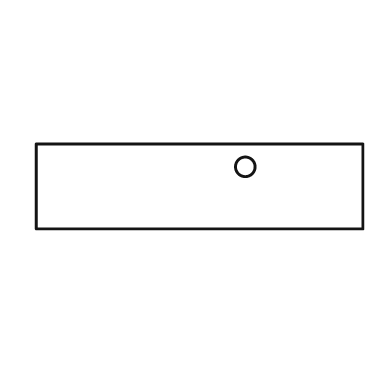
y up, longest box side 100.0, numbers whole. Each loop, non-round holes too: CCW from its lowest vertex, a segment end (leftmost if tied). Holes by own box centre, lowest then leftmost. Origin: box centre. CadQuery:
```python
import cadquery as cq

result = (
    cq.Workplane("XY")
    .moveTo(-50.0, -13.0)
    .lineTo(50.0, -13.0)
    .lineTo(50.0, 13.0)
    .lineTo(-50.0, 13.0)
    .close()
    .moveTo(14.0, 6.0)
    .circle(3.0)
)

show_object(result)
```